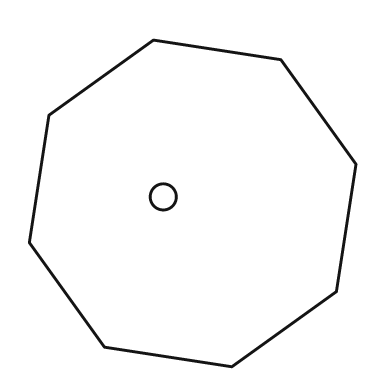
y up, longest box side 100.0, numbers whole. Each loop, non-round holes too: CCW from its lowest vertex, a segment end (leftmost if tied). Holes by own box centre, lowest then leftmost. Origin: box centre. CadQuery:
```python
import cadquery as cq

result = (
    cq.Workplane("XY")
    .moveTo(12.0, -50.0)
    .lineTo(44.0, -27.0)
    .lineTo(50.0, 12.0)
    .lineTo(27.0, 44.0)
    .lineTo(-12.0, 50.0)
    .lineTo(-44.0, 27.0)
    .lineTo(-50.0, -12.0)
    .lineTo(-27.0, -44.0)
    .close()
    .moveTo(-9.0, 2.0)
    .circle(4.0)
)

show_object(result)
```